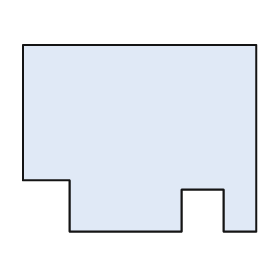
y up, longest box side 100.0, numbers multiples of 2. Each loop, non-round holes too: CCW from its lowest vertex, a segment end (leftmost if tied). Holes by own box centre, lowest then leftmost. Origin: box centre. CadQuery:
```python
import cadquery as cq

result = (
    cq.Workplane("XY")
    .moveTo(-30.0, -40.0)
    .lineTo(18.0, -40.0)
    .lineTo(18.0, -22.0)
    .lineTo(36.0, -22.0)
    .lineTo(36.0, -40.0)
    .lineTo(50.0, -40.0)
    .lineTo(50.0, 40.0)
    .lineTo(-50.0, 40.0)
    .lineTo(-50.0, -18.0)
    .lineTo(-30.0, -18.0)
    .close()
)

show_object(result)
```